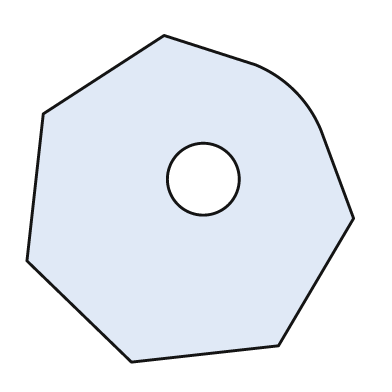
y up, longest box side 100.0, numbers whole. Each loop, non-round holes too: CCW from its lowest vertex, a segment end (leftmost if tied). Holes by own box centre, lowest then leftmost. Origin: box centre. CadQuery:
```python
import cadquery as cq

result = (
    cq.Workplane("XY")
    .moveTo(-18.0, -50.0)
    .lineTo(27.0, -45.0)
    .lineTo(50.0, -6.0)
    .lineTo(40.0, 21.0)
    .threePointArc((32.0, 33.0), (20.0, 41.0))
    .lineTo(-8.0, 50.0)
    .lineTo(-45.0, 26.0)
    .lineTo(-50.0, -19.0)
    .close()
    .moveTo(4.0, 6.0)
    .circle(11.0)
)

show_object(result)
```